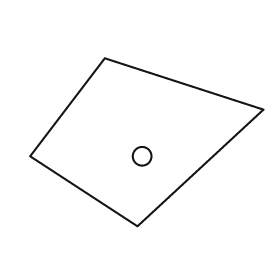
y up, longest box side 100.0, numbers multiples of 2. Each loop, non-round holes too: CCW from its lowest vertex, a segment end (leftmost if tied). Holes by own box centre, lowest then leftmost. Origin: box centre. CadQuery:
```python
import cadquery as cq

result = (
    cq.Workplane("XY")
    .moveTo(-4.0, -36.0)
    .lineTo(50.0, 14.0)
    .lineTo(-18.0, 36.0)
    .lineTo(-50.0, -6.0)
    .close()
    .moveTo(-2.0, -6.0)
    .circle(4.0)
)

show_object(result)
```